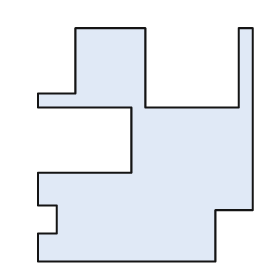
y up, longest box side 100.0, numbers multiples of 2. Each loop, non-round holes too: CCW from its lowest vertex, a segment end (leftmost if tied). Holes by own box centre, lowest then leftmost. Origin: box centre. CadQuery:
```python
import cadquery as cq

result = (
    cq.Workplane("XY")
    .moveTo(-46.0, -50.0)
    .lineTo(30.0, -50.0)
    .lineTo(30.0, -28.0)
    .lineTo(46.0, -28.0)
    .lineTo(46.0, 50.0)
    .lineTo(40.0, 50.0)
    .lineTo(40.0, 16.0)
    .lineTo(0.0, 16.0)
    .lineTo(0.0, 50.0)
    .lineTo(-30.0, 50.0)
    .lineTo(-30.0, 22.0)
    .lineTo(-46.0, 22.0)
    .lineTo(-46.0, 16.0)
    .lineTo(-6.0, 16.0)
    .lineTo(-6.0, -12.0)
    .lineTo(-46.0, -12.0)
    .lineTo(-46.0, -26.0)
    .lineTo(-38.0, -26.0)
    .lineTo(-38.0, -38.0)
    .lineTo(-46.0, -38.0)
    .close()
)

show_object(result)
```